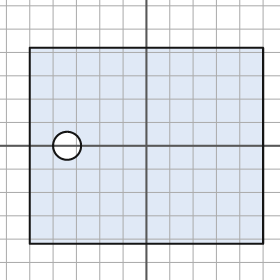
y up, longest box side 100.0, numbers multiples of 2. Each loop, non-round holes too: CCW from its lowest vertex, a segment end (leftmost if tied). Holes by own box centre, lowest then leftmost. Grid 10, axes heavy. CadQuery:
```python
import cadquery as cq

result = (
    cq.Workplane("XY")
    .moveTo(-50.0, -42.0)
    .lineTo(50.0, -42.0)
    .lineTo(50.0, 42.0)
    .lineTo(-50.0, 42.0)
    .close()
    .moveTo(-34.0, 0.0)
    .circle(6.0)
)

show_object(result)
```